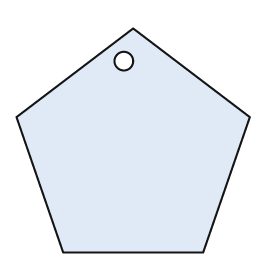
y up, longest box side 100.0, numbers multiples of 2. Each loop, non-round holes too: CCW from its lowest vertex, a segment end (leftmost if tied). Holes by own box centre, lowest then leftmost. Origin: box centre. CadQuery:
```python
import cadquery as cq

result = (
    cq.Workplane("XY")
    .moveTo(-30.0, -48.0)
    .lineTo(30.0, -48.0)
    .lineTo(50.0, 10.0)
    .lineTo(0.0, 48.0)
    .lineTo(-50.0, 10.0)
    .close()
    .moveTo(-4.0, 34.0)
    .circle(4.0)
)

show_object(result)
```